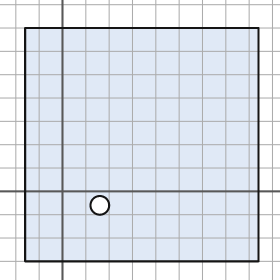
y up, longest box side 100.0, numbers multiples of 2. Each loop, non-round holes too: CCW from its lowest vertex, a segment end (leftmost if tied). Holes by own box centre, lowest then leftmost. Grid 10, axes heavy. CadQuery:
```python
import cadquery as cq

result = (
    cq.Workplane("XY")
    .moveTo(-16.0, -30.0)
    .lineTo(84.0, -30.0)
    .lineTo(84.0, 70.0)
    .lineTo(-16.0, 70.0)
    .close()
    .moveTo(16.0, -6.0)
    .circle(4.0)
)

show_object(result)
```